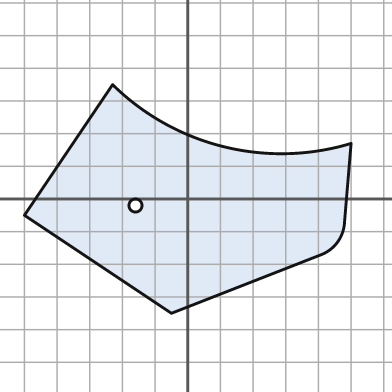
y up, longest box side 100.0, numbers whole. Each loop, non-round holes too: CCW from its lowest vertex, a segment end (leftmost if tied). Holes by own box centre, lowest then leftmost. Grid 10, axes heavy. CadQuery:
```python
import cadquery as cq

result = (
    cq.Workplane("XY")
    .moveTo(-5.0, -35.0)
    .lineTo(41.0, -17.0)
    .threePointArc((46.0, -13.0), (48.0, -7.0))
    .lineTo(50.0, 17.0)
    .threePointArc((11.0, 16.0), (-23.0, 35.0))
    .lineTo(-50.0, -5.0)
    .close()
    .moveTo(-16.0, -2.0)
    .circle(2.0)
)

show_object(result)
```